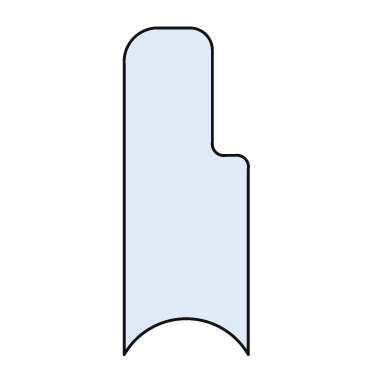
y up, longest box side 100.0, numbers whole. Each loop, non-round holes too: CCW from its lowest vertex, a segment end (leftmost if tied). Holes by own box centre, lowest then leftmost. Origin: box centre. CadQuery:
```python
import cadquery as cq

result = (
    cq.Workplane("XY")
    .moveTo(-19.0, -50.0)
    .threePointArc((0.0, -39.0), (19.0, -50.0))
    .lineTo(19.0, 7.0)
    .threePointArc((18.0, 10.0), (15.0, 11.0))
    .lineTo(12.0, 11.0)
    .threePointArc((9.0, 12.0), (8.0, 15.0))
    .lineTo(8.0, 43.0)
    .threePointArc((6.0, 48.0), (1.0, 50.0))
    .lineTo(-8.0, 50.0)
    .threePointArc((-16.0, 47.0), (-19.0, 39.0))
    .close()
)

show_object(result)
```